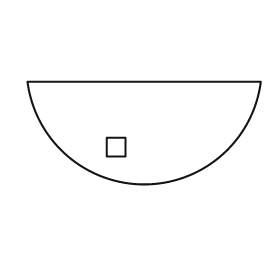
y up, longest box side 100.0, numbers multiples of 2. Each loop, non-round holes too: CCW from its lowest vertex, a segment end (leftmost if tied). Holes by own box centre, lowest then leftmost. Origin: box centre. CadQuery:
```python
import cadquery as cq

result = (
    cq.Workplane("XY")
    .moveTo(-50.0, 22.0)
    .threePointArc((0.0, -22.0), (50.0, 22.0))
    .close()
    .moveTo(-16.0, -10.0)
    .lineTo(-8.0, -10.0)
    .lineTo(-8.0, -2.0)
    .lineTo(-16.0, -2.0)
    .close()
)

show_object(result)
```